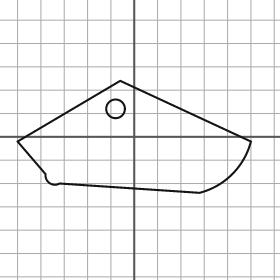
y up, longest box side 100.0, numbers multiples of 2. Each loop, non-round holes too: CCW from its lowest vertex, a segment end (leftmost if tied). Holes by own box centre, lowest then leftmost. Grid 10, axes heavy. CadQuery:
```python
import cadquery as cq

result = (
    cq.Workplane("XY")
    .moveTo(28.0, -24.0)
    .threePointArc((42.0, -16.0), (50.0, -2.0))
    .lineTo(-6.0, 24.0)
    .lineTo(-50.0, -2.0)
    .lineTo(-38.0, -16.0)
    .threePointArc((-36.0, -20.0), (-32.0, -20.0))
    .close()
    .moveTo(-8.0, 12.0)
    .circle(4.0)
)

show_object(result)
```